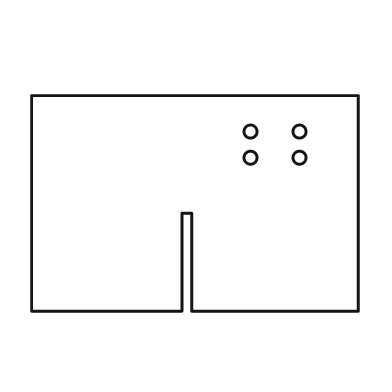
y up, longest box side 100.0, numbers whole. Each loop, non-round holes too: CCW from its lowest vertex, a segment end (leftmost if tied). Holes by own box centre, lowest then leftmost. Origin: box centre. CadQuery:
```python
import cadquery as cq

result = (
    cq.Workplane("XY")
    .moveTo(-50.0, -33.0)
    .lineTo(-4.0, -33.0)
    .lineTo(-4.0, -3.0)
    .lineTo(-1.0, -3.0)
    .lineTo(-1.0, -33.0)
    .lineTo(50.0, -33.0)
    .lineTo(50.0, 33.0)
    .lineTo(-50.0, 33.0)
    .close()
    .moveTo(17.0, 14.0)
    .circle(2.0)
    .moveTo(32.0, 14.0)
    .circle(2.0)
    .moveTo(17.0, 22.0)
    .circle(2.0)
    .moveTo(32.0, 22.0)
    .circle(2.0)
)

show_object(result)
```